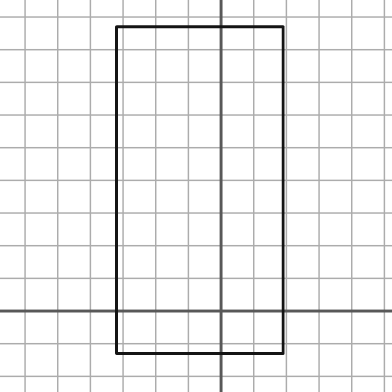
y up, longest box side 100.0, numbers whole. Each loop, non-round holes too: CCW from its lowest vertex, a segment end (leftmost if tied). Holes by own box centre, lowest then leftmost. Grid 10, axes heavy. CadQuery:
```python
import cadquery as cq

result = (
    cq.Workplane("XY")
    .moveTo(-32.0, -13.0)
    .lineTo(19.0, -13.0)
    .lineTo(19.0, 87.0)
    .lineTo(-32.0, 87.0)
    .close()
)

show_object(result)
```